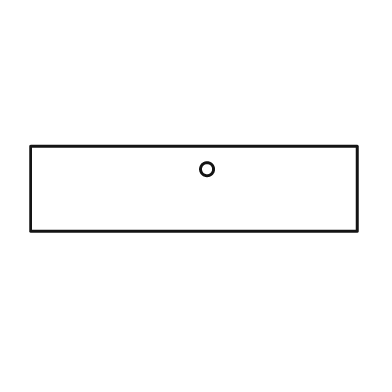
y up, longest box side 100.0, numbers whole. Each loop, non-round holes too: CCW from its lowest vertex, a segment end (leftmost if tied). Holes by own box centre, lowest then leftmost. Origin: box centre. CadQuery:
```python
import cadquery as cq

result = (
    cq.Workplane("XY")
    .moveTo(-50.0, -13.0)
    .lineTo(50.0, -13.0)
    .lineTo(50.0, 13.0)
    .lineTo(-50.0, 13.0)
    .close()
    .moveTo(4.0, 6.0)
    .circle(2.0)
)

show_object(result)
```